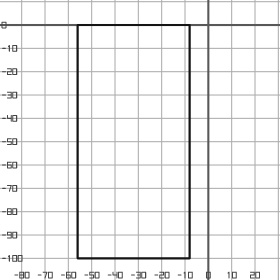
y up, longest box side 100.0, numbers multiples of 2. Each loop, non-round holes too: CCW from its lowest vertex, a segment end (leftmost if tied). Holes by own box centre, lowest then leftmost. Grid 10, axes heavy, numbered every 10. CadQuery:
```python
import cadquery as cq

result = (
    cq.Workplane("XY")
    .moveTo(-56.0, -100.0)
    .lineTo(-8.0, -100.0)
    .lineTo(-8.0, 0.0)
    .lineTo(-56.0, 0.0)
    .close()
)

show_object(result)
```